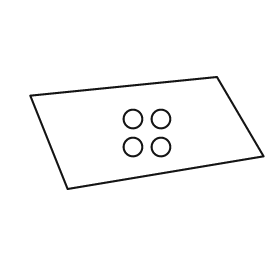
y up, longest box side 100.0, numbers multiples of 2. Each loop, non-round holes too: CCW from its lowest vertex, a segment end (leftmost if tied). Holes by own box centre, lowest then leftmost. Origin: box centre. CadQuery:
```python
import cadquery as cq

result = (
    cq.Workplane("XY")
    .moveTo(-34.0, -24.0)
    .lineTo(50.0, -10.0)
    .lineTo(30.0, 24.0)
    .lineTo(-50.0, 16.0)
    .close()
    .moveTo(-6.0, -6.0)
    .circle(4.0)
    .moveTo(6.0, -6.0)
    .circle(4.0)
    .moveTo(-6.0, 6.0)
    .circle(4.0)
    .moveTo(6.0, 6.0)
    .circle(4.0)
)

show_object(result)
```